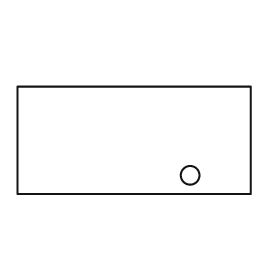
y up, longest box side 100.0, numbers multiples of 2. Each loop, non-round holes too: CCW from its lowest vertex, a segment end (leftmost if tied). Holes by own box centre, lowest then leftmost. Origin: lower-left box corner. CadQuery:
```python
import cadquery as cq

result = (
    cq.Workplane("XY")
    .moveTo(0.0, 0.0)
    .lineTo(100.0, 0.0)
    .lineTo(100.0, 46.0)
    .lineTo(0.0, 46.0)
    .close()
    .moveTo(74.0, 8.0)
    .circle(4.0)
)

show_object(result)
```